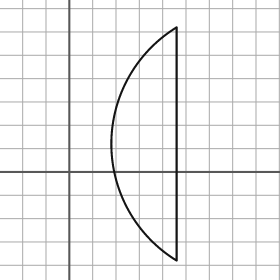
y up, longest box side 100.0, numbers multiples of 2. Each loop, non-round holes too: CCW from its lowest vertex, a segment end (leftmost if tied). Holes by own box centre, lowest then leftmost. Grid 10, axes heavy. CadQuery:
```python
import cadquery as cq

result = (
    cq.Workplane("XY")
    .moveTo(46.0, -38.0)
    .lineTo(46.0, 62.0)
    .threePointArc((18.0, 12.0), (46.0, -38.0))
    .close()
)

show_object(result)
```